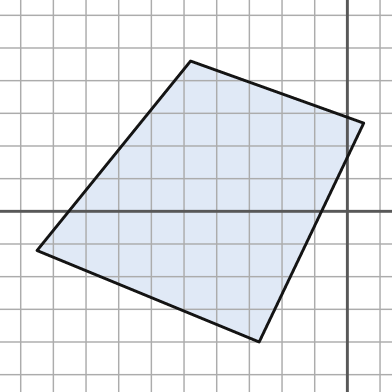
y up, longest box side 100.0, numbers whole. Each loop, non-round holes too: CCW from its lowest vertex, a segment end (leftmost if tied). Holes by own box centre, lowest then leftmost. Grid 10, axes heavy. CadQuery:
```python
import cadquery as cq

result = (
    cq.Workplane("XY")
    .moveTo(-27.0, -40.0)
    .lineTo(5.0, 27.0)
    .lineTo(-48.0, 46.0)
    .lineTo(-95.0, -12.0)
    .close()
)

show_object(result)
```